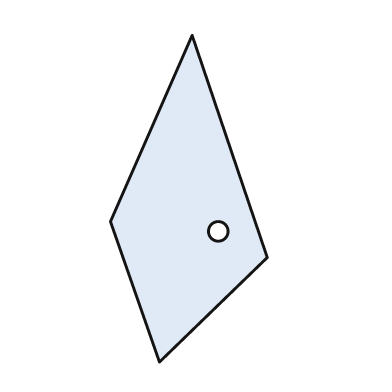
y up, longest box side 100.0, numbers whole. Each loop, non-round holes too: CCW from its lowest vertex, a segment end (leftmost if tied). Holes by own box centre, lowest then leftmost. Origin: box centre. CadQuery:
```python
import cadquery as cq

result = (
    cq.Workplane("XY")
    .moveTo(-9.0, -50.0)
    .lineTo(24.0, -18.0)
    .lineTo(1.0, 50.0)
    .lineTo(-24.0, -7.0)
    .close()
    .moveTo(9.0, -10.0)
    .circle(3.0)
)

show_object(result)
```